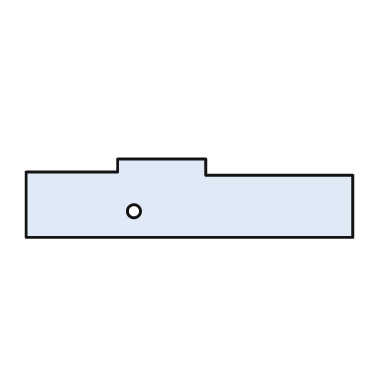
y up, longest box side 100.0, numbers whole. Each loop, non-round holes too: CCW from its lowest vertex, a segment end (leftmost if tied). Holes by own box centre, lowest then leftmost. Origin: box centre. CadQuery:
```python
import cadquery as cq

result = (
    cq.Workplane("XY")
    .moveTo(-50.0, -12.0)
    .lineTo(50.0, -12.0)
    .lineTo(50.0, 7.0)
    .lineTo(5.0, 7.0)
    .lineTo(5.0, 12.0)
    .lineTo(-22.0, 12.0)
    .lineTo(-22.0, 8.0)
    .lineTo(-50.0, 8.0)
    .close()
    .moveTo(-17.0, -4.0)
    .circle(2.0)
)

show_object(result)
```